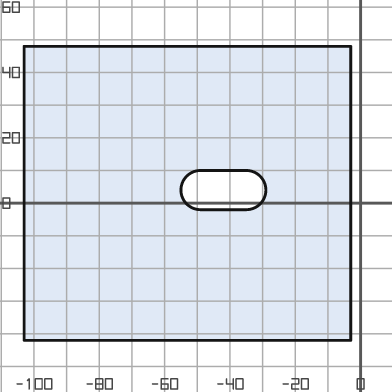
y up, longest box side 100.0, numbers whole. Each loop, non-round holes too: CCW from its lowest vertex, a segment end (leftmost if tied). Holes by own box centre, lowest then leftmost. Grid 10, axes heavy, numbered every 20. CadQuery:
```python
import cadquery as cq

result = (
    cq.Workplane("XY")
    .moveTo(-103.0, -42.0)
    .lineTo(-3.0, -42.0)
    .lineTo(-3.0, 48.0)
    .lineTo(-103.0, 48.0)
    .close()
    .moveTo(-49.0, -2.0)
    .lineTo(-35.0, -2.0)
    .threePointArc((-29.0, 4.0), (-35.0, 10.0))
    .lineTo(-49.0, 10.0)
    .threePointArc((-55.0, 4.0), (-49.0, -2.0))
    .close()
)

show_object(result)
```